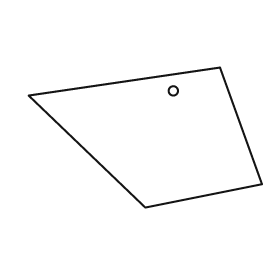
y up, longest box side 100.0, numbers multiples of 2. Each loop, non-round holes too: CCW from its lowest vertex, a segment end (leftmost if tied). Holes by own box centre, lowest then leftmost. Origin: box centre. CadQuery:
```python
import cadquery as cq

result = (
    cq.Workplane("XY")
    .moveTo(0.0, -30.0)
    .lineTo(50.0, -20.0)
    .lineTo(32.0, 30.0)
    .lineTo(-50.0, 18.0)
    .close()
    .moveTo(12.0, 20.0)
    .circle(2.0)
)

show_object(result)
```